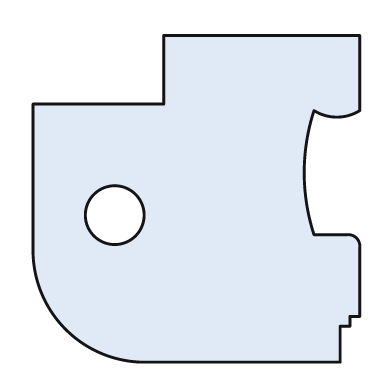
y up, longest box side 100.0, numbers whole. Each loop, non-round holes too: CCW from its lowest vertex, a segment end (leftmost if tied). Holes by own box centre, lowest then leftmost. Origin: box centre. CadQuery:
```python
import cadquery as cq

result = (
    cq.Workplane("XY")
    .moveTo(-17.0, -50.0)
    .lineTo(44.0, -50.0)
    .lineTo(44.0, -39.0)
    .lineTo(47.0, -39.0)
    .lineTo(47.0, -36.0)
    .lineTo(50.0, -36.0)
    .lineTo(50.0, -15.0)
    .threePointArc((49.0, -12.0), (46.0, -11.0))
    .lineTo(36.0, -11.0)
    .threePointArc((33.0, 8.0), (36.0, 27.0))
    .threePointArc((43.0, 25.0), (50.0, 27.0))
    .lineTo(50.0, 50.0)
    .lineTo(-10.0, 50.0)
    .lineTo(-10.0, 29.0)
    .lineTo(-50.0, 29.0)
    .lineTo(-50.0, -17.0)
    .threePointArc((-40.0, -40.0), (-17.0, -50.0))
    .close()
    .moveTo(-25.0, -5.0)
    .circle(9.0)
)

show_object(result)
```